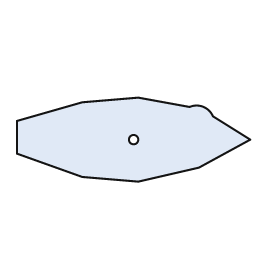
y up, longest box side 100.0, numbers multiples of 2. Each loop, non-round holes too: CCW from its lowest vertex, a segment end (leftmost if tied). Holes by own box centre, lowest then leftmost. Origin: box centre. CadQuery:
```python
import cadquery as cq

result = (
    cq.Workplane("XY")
    .moveTo(2.0, -18.0)
    .lineTo(28.0, -12.0)
    .lineTo(50.0, 0.0)
    .lineTo(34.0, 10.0)
    .threePointArc((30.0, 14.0), (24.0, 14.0))
    .lineTo(2.0, 18.0)
    .lineTo(-22.0, 16.0)
    .lineTo(-50.0, 8.0)
    .lineTo(-50.0, -6.0)
    .lineTo(-22.0, -16.0)
    .close()
    .moveTo(0.0, 0.0)
    .circle(2.0)
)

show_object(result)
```